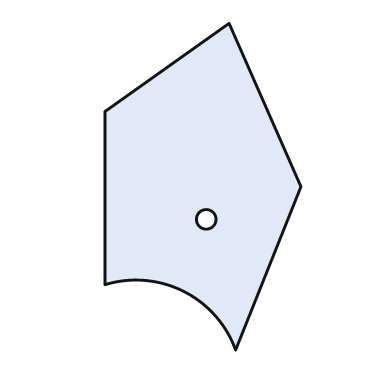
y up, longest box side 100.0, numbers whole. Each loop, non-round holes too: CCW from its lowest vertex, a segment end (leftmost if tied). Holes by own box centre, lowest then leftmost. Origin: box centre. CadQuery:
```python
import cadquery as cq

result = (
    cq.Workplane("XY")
    .moveTo(10.0, -50.0)
    .lineTo(30.0, 0.0)
    .lineTo(8.0, 50.0)
    .lineTo(-30.0, 23.0)
    .lineTo(-30.0, -30.0)
    .threePointArc((-6.0, -32.0), (10.0, -50.0))
    .close()
    .moveTo(1.0, -10.0)
    .circle(3.0)
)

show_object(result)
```